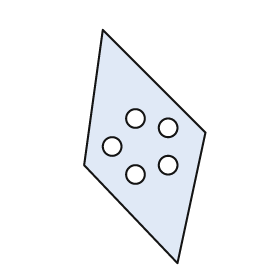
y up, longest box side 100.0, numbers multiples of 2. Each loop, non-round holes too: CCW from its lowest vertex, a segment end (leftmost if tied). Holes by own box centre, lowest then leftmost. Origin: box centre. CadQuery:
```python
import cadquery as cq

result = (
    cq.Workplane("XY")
    .moveTo(14.0, -50.0)
    .lineTo(26.0, 6.0)
    .lineTo(-18.0, 50.0)
    .lineTo(-26.0, -8.0)
    .close()
    .moveTo(-4.0, -12.0)
    .circle(4.0)
    .moveTo(10.0, -8.0)
    .circle(4.0)
    .moveTo(-14.0, 0.0)
    .circle(4.0)
    .moveTo(10.0, 8.0)
    .circle(4.0)
    .moveTo(-4.0, 12.0)
    .circle(4.0)
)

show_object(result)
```